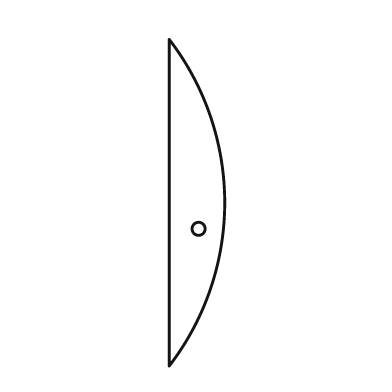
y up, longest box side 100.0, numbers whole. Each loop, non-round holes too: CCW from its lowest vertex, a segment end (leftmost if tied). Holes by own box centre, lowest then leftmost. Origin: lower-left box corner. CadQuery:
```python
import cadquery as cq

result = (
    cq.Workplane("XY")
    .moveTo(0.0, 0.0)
    .threePointArc((17.0, 50.0), (0.0, 100.0))
    .close()
    .moveTo(9.0, 42.0)
    .circle(2.0)
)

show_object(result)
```